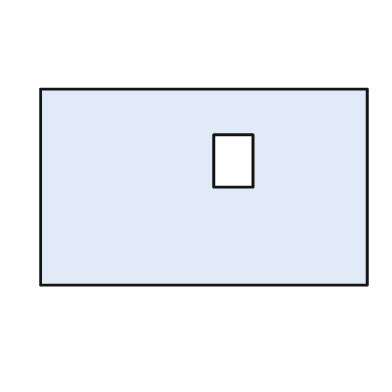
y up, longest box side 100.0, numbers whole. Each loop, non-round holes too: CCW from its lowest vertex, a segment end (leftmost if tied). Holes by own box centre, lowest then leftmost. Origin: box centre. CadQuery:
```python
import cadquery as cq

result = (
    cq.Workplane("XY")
    .moveTo(-50.0, -30.0)
    .lineTo(50.0, -30.0)
    .lineTo(50.0, 30.0)
    .lineTo(-50.0, 30.0)
    .close()
    .moveTo(3.0, 0.0)
    .lineTo(15.0, 0.0)
    .lineTo(15.0, 16.0)
    .lineTo(3.0, 16.0)
    .close()
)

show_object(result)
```